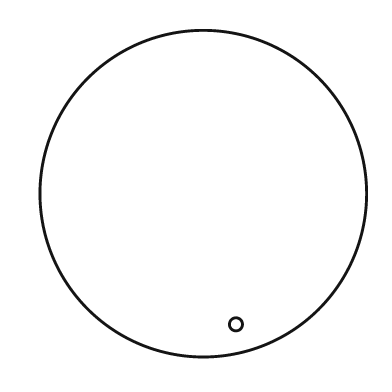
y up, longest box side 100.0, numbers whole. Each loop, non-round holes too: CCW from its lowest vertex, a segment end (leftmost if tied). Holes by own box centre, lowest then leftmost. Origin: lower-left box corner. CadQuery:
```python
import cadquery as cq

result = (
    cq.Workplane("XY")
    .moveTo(50.0, 50.0)
    .circle(50.0)
    .moveTo(60.0, 10.0)
    .circle(2.0)
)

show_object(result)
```